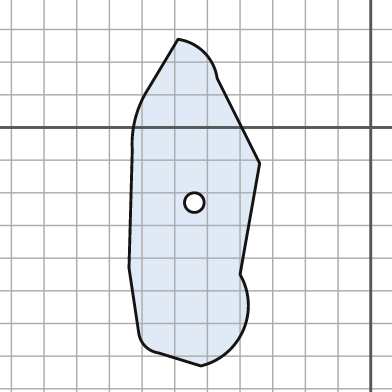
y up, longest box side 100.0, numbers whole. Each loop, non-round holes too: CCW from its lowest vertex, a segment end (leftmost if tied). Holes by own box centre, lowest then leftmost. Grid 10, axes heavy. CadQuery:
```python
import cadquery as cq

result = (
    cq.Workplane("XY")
    .moveTo(-52.0, -73.0)
    .threePointArc((-39.0, -62.0), (-40.0, -45.0))
    .lineTo(-34.0, -11.0)
    .lineTo(-47.0, 15.0)
    .threePointArc((-51.0, 23.0), (-59.0, 27.0))
    .lineTo(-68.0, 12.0)
    .threePointArc((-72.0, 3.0), (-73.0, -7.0))
    .lineTo(-74.0, -43.0)
    .lineTo(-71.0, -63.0)
    .threePointArc((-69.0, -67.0), (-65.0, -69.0))
    .close()
    .moveTo(-54.0, -23.0)
    .circle(3.0)
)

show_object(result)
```